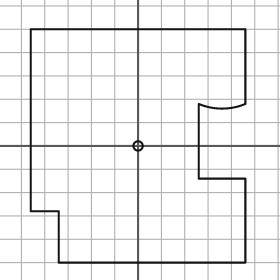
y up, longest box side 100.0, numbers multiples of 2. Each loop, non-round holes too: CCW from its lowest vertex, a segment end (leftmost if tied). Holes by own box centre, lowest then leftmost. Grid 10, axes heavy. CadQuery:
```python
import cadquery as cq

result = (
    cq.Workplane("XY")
    .moveTo(-34.0, -50.0)
    .lineTo(46.0, -50.0)
    .lineTo(46.0, -14.0)
    .lineTo(26.0, -14.0)
    .lineTo(26.0, 18.0)
    .threePointArc((36.0, 16.0), (46.0, 18.0))
    .lineTo(46.0, 50.0)
    .lineTo(-46.0, 50.0)
    .lineTo(-46.0, -28.0)
    .lineTo(-34.0, -28.0)
    .close()
    .moveTo(0.0, 0.0)
    .circle(2.0)
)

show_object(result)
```